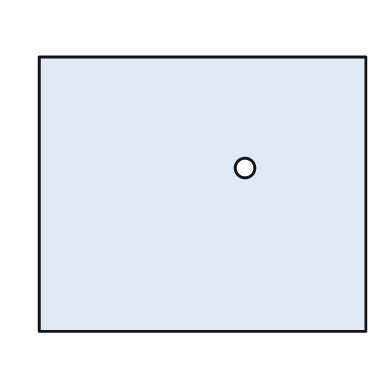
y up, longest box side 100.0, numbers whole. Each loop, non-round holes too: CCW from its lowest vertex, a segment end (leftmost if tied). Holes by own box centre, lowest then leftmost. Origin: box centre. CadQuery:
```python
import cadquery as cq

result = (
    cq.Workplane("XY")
    .moveTo(-50.0, -42.0)
    .lineTo(50.0, -42.0)
    .lineTo(50.0, 42.0)
    .lineTo(-50.0, 42.0)
    .close()
    .moveTo(13.0, 8.0)
    .circle(3.0)
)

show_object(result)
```